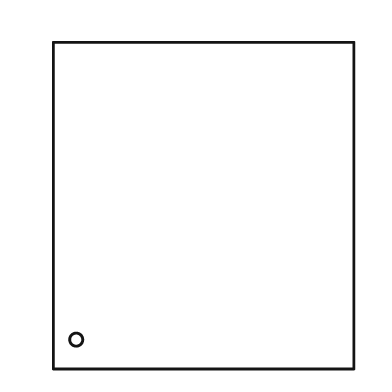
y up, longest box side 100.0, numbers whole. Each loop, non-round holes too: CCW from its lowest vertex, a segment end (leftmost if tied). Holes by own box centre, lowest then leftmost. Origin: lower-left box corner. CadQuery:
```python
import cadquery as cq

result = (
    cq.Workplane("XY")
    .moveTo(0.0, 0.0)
    .lineTo(92.0, 0.0)
    .lineTo(92.0, 100.0)
    .lineTo(0.0, 100.0)
    .close()
    .moveTo(7.0, 9.0)
    .circle(2.0)
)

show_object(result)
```